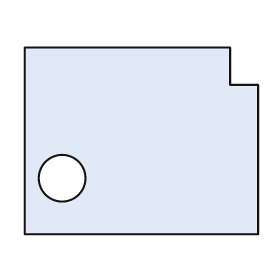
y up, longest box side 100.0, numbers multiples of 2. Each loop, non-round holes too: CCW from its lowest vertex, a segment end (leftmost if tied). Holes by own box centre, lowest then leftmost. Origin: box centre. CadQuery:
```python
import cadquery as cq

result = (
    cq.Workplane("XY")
    .moveTo(-50.0, -40.0)
    .lineTo(50.0, -40.0)
    .lineTo(50.0, 24.0)
    .lineTo(38.0, 24.0)
    .lineTo(38.0, 40.0)
    .lineTo(-50.0, 40.0)
    .close()
    .moveTo(-34.0, -16.0)
    .circle(10.0)
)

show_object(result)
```